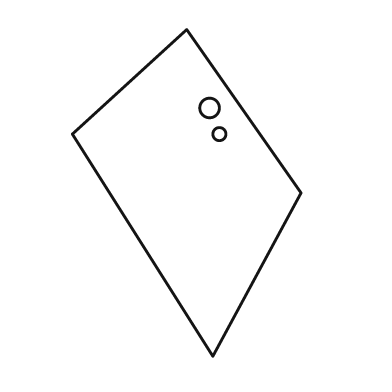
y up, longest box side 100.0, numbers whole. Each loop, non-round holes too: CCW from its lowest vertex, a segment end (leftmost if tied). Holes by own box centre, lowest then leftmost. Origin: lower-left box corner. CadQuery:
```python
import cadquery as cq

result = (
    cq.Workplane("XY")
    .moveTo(43.0, 0.0)
    .lineTo(70.0, 50.0)
    .lineTo(35.0, 100.0)
    .lineTo(0.0, 68.0)
    .close()
    .moveTo(45.0, 68.0)
    .circle(2.0)
    .moveTo(42.0, 76.0)
    .circle(3.0)
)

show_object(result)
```